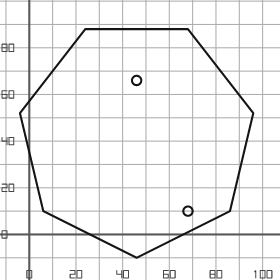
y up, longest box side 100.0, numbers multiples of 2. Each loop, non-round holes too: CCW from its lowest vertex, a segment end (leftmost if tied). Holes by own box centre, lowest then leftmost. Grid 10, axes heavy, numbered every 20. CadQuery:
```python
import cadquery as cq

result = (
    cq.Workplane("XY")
    .moveTo(46.0, -10.0)
    .lineTo(86.0, 10.0)
    .lineTo(96.0, 52.0)
    .lineTo(68.0, 88.0)
    .lineTo(24.0, 88.0)
    .lineTo(-4.0, 52.0)
    .lineTo(6.0, 10.0)
    .close()
    .moveTo(68.0, 10.0)
    .circle(2.0)
    .moveTo(46.0, 66.0)
    .circle(2.0)
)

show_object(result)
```